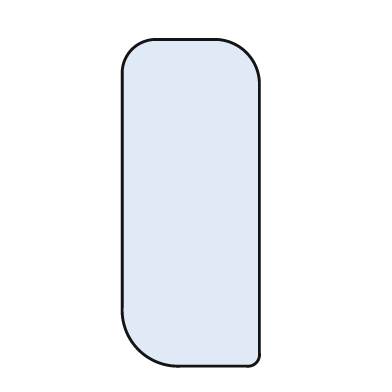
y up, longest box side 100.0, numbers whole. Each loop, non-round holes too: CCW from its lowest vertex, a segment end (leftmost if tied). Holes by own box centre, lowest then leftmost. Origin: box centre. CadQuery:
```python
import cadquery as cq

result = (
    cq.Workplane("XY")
    .moveTo(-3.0, -50.0)
    .lineTo(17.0, -50.0)
    .threePointArc((20.0, -49.0), (21.0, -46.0))
    .lineTo(21.0, 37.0)
    .threePointArc((17.0, 46.0), (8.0, 50.0))
    .lineTo(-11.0, 50.0)
    .threePointArc((-18.0, 47.0), (-21.0, 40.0))
    .lineTo(-21.0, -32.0)
    .threePointArc((-16.0, -45.0), (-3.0, -50.0))
    .close()
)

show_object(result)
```